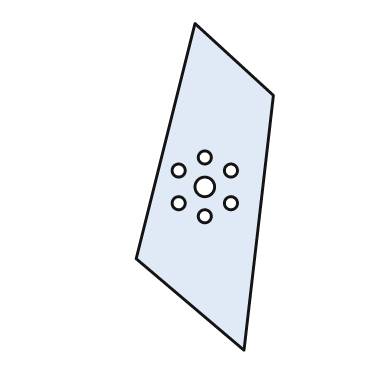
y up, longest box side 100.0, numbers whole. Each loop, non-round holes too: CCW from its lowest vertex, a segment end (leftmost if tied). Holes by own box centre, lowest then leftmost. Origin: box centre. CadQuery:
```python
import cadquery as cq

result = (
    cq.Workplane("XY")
    .moveTo(12.0, -50.0)
    .lineTo(21.0, 28.0)
    .lineTo(-3.0, 50.0)
    .lineTo(-21.0, -22.0)
    .close()
    .moveTo(0.0, -9.0)
    .circle(2.0)
    .moveTo(-8.0, -5.0)
    .circle(2.0)
    .moveTo(8.0, -5.0)
    .circle(2.0)
    .moveTo(0.0, 0.0)
    .circle(3.0)
    .moveTo(-8.0, 5.0)
    .circle(2.0)
    .moveTo(8.0, 5.0)
    .circle(2.0)
    .moveTo(0.0, 9.0)
    .circle(2.0)
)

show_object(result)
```